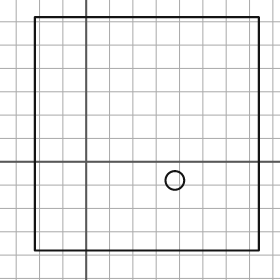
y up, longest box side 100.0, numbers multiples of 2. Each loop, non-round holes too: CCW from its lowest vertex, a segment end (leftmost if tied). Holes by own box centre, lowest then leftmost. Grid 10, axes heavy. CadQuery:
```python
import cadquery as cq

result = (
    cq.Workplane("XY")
    .moveTo(-22.0, -38.0)
    .lineTo(74.0, -38.0)
    .lineTo(74.0, 62.0)
    .lineTo(-22.0, 62.0)
    .close()
    .moveTo(38.0, -8.0)
    .circle(4.0)
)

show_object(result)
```